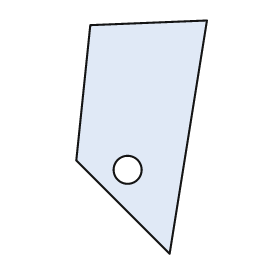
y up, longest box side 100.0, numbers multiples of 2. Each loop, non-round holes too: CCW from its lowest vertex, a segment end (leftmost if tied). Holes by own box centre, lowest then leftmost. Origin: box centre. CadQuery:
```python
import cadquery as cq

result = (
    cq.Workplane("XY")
    .moveTo(12.0, -50.0)
    .lineTo(28.0, 50.0)
    .lineTo(-22.0, 48.0)
    .lineTo(-28.0, -10.0)
    .close()
    .moveTo(-6.0, -14.0)
    .circle(6.0)
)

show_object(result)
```